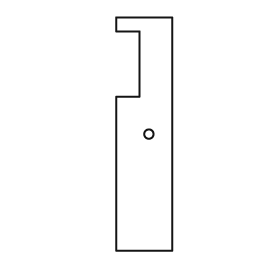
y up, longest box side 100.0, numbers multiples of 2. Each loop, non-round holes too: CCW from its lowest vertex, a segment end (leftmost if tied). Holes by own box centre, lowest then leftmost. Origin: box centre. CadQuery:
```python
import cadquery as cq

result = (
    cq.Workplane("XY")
    .moveTo(-12.0, -50.0)
    .lineTo(12.0, -50.0)
    .lineTo(12.0, 50.0)
    .lineTo(-12.0, 50.0)
    .lineTo(-12.0, 44.0)
    .lineTo(-2.0, 44.0)
    .lineTo(-2.0, 16.0)
    .lineTo(-12.0, 16.0)
    .close()
    .moveTo(2.0, 0.0)
    .circle(2.0)
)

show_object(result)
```